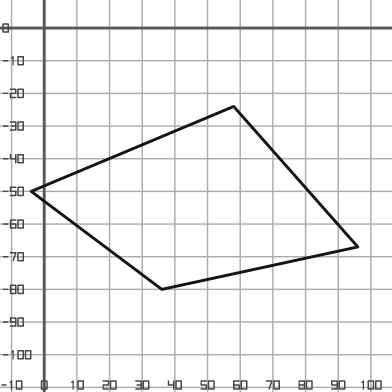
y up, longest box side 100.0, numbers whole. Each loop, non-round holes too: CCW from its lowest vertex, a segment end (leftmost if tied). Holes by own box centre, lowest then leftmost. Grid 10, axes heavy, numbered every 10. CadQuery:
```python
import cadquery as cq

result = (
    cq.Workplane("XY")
    .moveTo(36.0, -80.0)
    .lineTo(96.0, -67.0)
    .lineTo(58.0, -24.0)
    .lineTo(-4.0, -50.0)
    .close()
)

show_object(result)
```